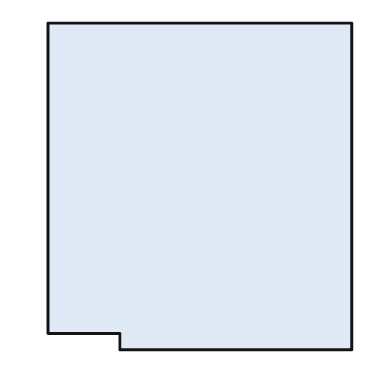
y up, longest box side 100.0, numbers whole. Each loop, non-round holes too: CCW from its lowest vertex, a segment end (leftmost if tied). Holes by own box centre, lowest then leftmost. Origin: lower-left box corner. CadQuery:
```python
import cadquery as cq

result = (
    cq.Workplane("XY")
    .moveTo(22.0, 0.0)
    .lineTo(93.0, 0.0)
    .lineTo(93.0, 100.0)
    .lineTo(0.0, 100.0)
    .lineTo(0.0, 5.0)
    .lineTo(22.0, 5.0)
    .close()
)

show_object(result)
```